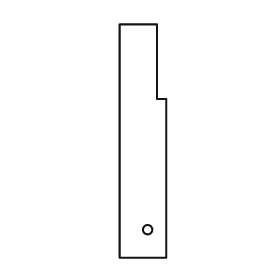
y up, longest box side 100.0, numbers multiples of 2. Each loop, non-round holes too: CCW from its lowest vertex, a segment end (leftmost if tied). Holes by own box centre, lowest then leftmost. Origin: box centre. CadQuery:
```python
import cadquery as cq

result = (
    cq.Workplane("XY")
    .moveTo(-10.0, -50.0)
    .lineTo(10.0, -50.0)
    .lineTo(10.0, 18.0)
    .lineTo(6.0, 18.0)
    .lineTo(6.0, 50.0)
    .lineTo(-10.0, 50.0)
    .close()
    .moveTo(2.0, -38.0)
    .circle(2.0)
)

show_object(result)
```